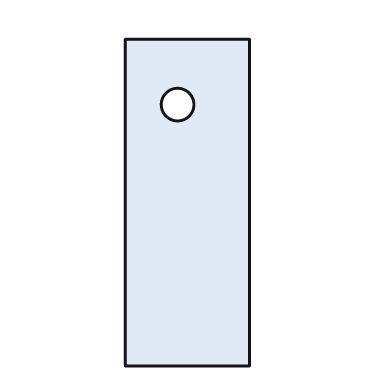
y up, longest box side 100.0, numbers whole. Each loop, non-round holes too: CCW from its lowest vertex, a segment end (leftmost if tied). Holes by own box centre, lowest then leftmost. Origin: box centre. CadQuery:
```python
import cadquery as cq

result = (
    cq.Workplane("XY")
    .moveTo(-19.0, -50.0)
    .lineTo(19.0, -50.0)
    .lineTo(19.0, 50.0)
    .lineTo(-19.0, 50.0)
    .close()
    .moveTo(-3.0, 30.0)
    .circle(5.0)
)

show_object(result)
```